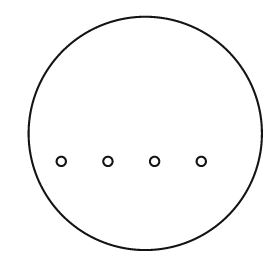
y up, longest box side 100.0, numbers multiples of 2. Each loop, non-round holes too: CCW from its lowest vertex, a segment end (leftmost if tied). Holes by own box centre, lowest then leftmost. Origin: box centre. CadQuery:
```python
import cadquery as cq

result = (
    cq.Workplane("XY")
    .moveTo(0.0, 0.0)
    .circle(50.0)
    .moveTo(-36.0, -12.0)
    .circle(2.0)
    .moveTo(-16.0, -12.0)
    .circle(2.0)
    .moveTo(4.0, -12.0)
    .circle(2.0)
    .moveTo(24.0, -12.0)
    .circle(2.0)
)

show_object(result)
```